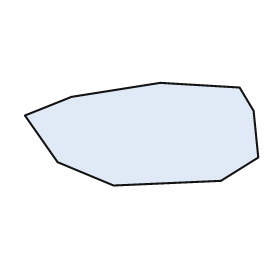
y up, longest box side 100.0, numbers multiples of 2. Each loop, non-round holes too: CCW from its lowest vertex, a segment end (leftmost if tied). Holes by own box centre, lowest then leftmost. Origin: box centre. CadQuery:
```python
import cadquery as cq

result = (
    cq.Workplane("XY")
    .moveTo(-12.0, -22.0)
    .lineTo(34.0, -20.0)
    .lineTo(50.0, -10.0)
    .lineTo(48.0, 10.0)
    .lineTo(42.0, 20.0)
    .lineTo(8.0, 22.0)
    .lineTo(-30.0, 16.0)
    .lineTo(-50.0, 8.0)
    .lineTo(-36.0, -12.0)
    .close()
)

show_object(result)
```